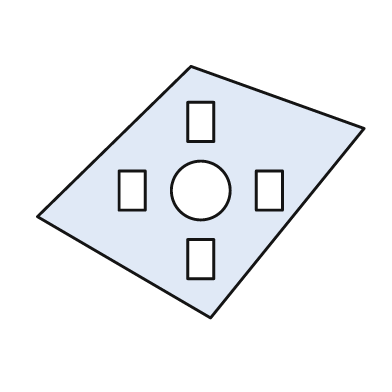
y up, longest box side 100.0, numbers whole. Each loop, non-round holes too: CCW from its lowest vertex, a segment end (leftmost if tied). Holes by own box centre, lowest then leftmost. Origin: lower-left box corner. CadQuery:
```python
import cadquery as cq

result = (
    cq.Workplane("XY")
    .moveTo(53.0, 0.0)
    .lineTo(100.0, 58.0)
    .lineTo(47.0, 77.0)
    .lineTo(0.0, 31.0)
    .close()
    .moveTo(46.0, 12.0)
    .lineTo(54.0, 12.0)
    .lineTo(54.0, 24.0)
    .lineTo(46.0, 24.0)
    .close()
    .moveTo(25.0, 33.0)
    .lineTo(33.0, 33.0)
    .lineTo(33.0, 45.0)
    .lineTo(25.0, 45.0)
    .close()
    .moveTo(50.0, 39.0)
    .circle(9.0)
    .moveTo(67.0, 33.0)
    .lineTo(75.0, 33.0)
    .lineTo(75.0, 45.0)
    .lineTo(67.0, 45.0)
    .close()
    .moveTo(46.0, 54.0)
    .lineTo(54.0, 54.0)
    .lineTo(54.0, 66.0)
    .lineTo(46.0, 66.0)
    .close()
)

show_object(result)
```